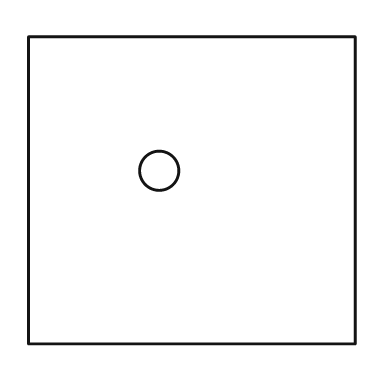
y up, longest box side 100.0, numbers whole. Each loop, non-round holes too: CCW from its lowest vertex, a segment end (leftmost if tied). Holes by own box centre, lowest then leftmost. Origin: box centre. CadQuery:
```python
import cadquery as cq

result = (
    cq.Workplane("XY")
    .moveTo(-50.0, -47.0)
    .lineTo(50.0, -47.0)
    .lineTo(50.0, 47.0)
    .lineTo(-50.0, 47.0)
    .close()
    .moveTo(-10.0, 6.0)
    .circle(6.0)
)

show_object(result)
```